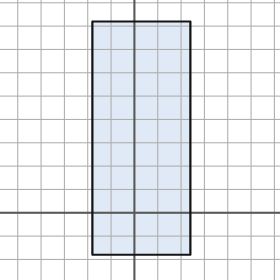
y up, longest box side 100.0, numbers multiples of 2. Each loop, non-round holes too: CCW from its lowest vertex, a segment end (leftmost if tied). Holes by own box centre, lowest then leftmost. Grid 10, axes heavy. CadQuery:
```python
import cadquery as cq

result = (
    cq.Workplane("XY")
    .moveTo(-18.0, -18.0)
    .lineTo(24.0, -18.0)
    .lineTo(24.0, 82.0)
    .lineTo(-18.0, 82.0)
    .close()
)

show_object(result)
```